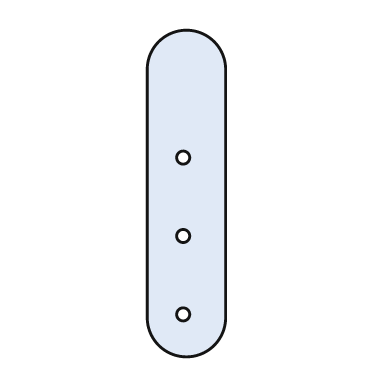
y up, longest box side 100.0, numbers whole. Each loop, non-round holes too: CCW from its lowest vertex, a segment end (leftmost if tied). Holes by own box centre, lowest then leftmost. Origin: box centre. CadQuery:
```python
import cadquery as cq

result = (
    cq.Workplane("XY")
    .moveTo(-12.0, -38.0)
    .threePointArc((0.0, -50.0), (12.0, -38.0))
    .lineTo(12.0, 38.0)
    .threePointArc((0.0, 50.0), (-12.0, 38.0))
    .close()
    .moveTo(-1.0, -37.0)
    .circle(2.0)
    .moveTo(-1.0, -13.0)
    .circle(2.0)
    .moveTo(-1.0, 11.0)
    .circle(2.0)
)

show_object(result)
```